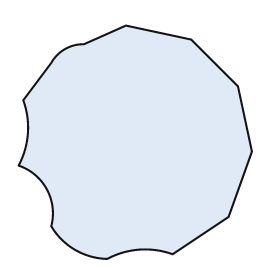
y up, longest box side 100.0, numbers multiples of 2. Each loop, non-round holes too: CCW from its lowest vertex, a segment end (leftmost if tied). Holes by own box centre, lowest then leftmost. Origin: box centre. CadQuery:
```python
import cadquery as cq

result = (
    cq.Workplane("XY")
    .moveTo(-12.0, -50.0)
    .threePointArc((2.0, -46.0), (16.0, -48.0))
    .lineTo(40.0, -32.0)
    .lineTo(50.0, -4.0)
    .lineTo(44.0, 24.0)
    .lineTo(24.0, 44.0)
    .lineTo(-4.0, 50.0)
    .lineTo(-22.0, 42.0)
    .threePointArc((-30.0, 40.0), (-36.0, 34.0))
    .lineTo(-48.0, 18.0)
    .threePointArc((-46.0, 4.0), (-50.0, -10.0))
    .threePointArc((-38.0, -20.0), (-36.0, -36.0))
    .threePointArc((-26.0, -46.0), (-12.0, -50.0))
    .close()
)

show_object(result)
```